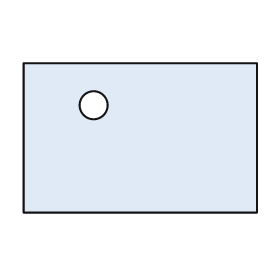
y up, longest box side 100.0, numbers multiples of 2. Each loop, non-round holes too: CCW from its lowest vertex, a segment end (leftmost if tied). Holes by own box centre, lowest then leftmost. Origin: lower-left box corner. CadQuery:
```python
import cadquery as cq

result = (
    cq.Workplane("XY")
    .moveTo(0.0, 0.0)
    .lineTo(100.0, 0.0)
    .lineTo(100.0, 64.0)
    .lineTo(0.0, 64.0)
    .close()
    .moveTo(30.0, 46.0)
    .circle(6.0)
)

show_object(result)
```